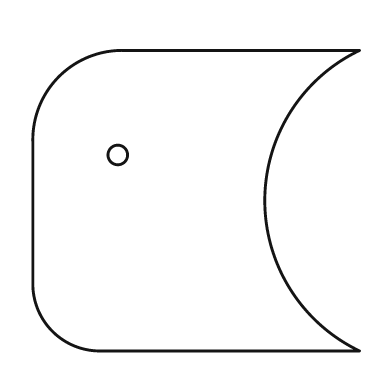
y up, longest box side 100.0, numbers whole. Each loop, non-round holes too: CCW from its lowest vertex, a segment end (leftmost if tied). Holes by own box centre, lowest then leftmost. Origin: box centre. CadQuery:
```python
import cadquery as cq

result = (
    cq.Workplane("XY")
    .moveTo(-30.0, -46.0)
    .lineTo(50.0, -46.0)
    .threePointArc((21.0, 0.0), (50.0, 46.0))
    .lineTo(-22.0, 46.0)
    .threePointArc((-42.0, 38.0), (-50.0, 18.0))
    .lineTo(-50.0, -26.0)
    .threePointArc((-44.0, -40.0), (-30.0, -46.0))
    .close()
    .moveTo(-24.0, 14.0)
    .circle(3.0)
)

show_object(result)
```